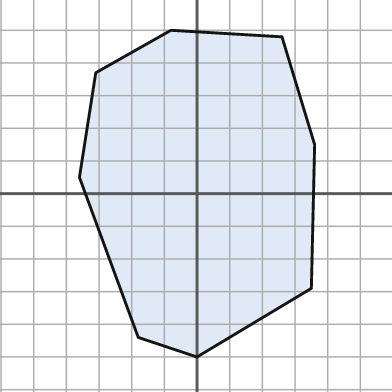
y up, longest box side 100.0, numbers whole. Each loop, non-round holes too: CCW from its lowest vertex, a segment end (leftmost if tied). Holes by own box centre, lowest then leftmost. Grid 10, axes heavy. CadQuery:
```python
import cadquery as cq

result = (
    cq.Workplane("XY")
    .moveTo(0.0, -50.0)
    .lineTo(35.0, -29.0)
    .lineTo(36.0, 15.0)
    .lineTo(26.0, 48.0)
    .lineTo(-8.0, 50.0)
    .lineTo(-31.0, 37.0)
    .lineTo(-36.0, 5.0)
    .lineTo(-18.0, -44.0)
    .close()
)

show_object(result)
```